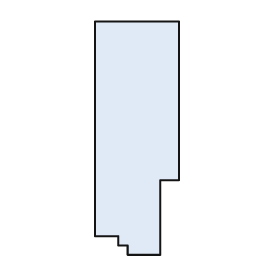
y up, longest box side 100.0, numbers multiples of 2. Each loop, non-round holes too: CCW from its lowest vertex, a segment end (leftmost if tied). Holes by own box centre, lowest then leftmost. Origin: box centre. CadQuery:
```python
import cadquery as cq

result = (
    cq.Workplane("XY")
    .moveTo(-4.0, -50.0)
    .lineTo(10.0, -50.0)
    .lineTo(10.0, -18.0)
    .lineTo(18.0, -18.0)
    .lineTo(18.0, 50.0)
    .lineTo(-18.0, 50.0)
    .lineTo(-18.0, -42.0)
    .lineTo(-8.0, -42.0)
    .lineTo(-8.0, -46.0)
    .lineTo(-4.0, -46.0)
    .close()
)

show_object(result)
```